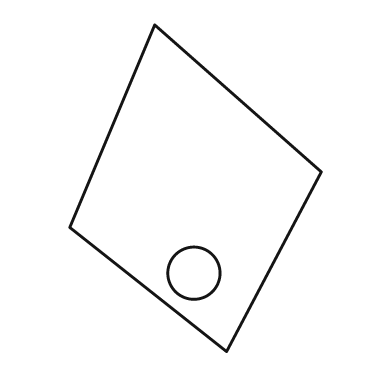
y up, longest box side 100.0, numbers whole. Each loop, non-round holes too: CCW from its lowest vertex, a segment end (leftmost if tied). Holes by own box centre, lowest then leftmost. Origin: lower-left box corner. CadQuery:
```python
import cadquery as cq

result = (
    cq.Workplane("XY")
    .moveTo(48.0, 0.0)
    .lineTo(77.0, 55.0)
    .lineTo(26.0, 100.0)
    .lineTo(0.0, 38.0)
    .close()
    .moveTo(38.0, 24.0)
    .circle(8.0)
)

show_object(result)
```